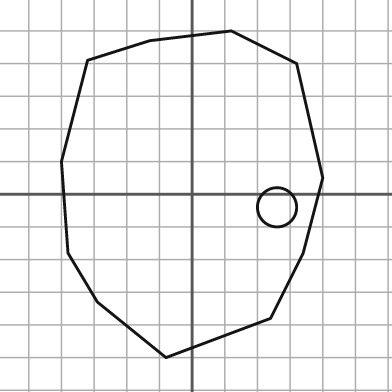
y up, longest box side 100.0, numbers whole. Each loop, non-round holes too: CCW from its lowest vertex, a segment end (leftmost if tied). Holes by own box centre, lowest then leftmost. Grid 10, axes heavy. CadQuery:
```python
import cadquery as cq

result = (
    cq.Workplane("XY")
    .moveTo(-8.0, -50.0)
    .lineTo(24.0, -38.0)
    .lineTo(34.0, -18.0)
    .lineTo(40.0, 5.0)
    .lineTo(32.0, 40.0)
    .lineTo(12.0, 50.0)
    .lineTo(-13.0, 47.0)
    .lineTo(-32.0, 41.0)
    .lineTo(-40.0, 10.0)
    .lineTo(-38.0, -18.0)
    .lineTo(-29.0, -33.0)
    .close()
    .moveTo(26.0, -4.0)
    .circle(6.0)
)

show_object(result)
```